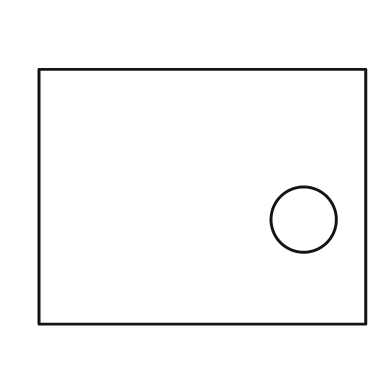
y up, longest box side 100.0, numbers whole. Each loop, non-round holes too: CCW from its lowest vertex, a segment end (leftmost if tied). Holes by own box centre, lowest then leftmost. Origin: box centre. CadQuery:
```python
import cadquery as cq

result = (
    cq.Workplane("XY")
    .moveTo(-50.0, -39.0)
    .lineTo(50.0, -39.0)
    .lineTo(50.0, 39.0)
    .lineTo(-50.0, 39.0)
    .close()
    .moveTo(31.0, -7.0)
    .circle(10.0)
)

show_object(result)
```